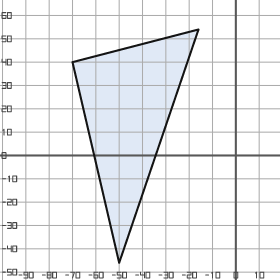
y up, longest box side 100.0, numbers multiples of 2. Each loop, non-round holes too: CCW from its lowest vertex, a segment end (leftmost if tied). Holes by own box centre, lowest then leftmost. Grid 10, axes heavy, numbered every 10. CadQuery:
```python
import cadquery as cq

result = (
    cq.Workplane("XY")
    .moveTo(-50.0, -46.0)
    .lineTo(-16.0, 54.0)
    .lineTo(-70.0, 40.0)
    .close()
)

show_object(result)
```